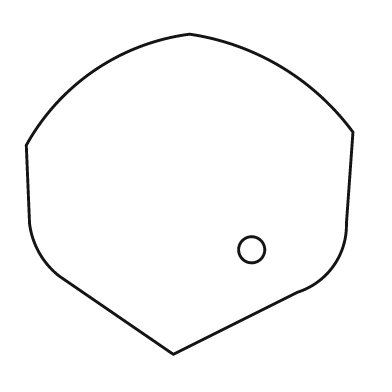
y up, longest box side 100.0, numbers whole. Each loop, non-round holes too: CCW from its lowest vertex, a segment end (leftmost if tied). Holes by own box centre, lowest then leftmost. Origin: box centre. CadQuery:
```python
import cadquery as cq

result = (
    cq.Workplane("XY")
    .moveTo(-5.0, -49.0)
    .lineTo(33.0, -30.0)
    .threePointArc((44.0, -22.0), (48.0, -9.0))
    .lineTo(50.0, 19.0)
    .threePointArc((28.0, 39.0), (0.0, 49.0))
    .threePointArc((-29.0, 38.0), (-50.0, 15.0))
    .lineTo(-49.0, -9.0)
    .threePointArc((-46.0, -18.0), (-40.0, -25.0))
    .close()
    .moveTo(19.0, -17.0)
    .circle(4.0)
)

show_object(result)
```